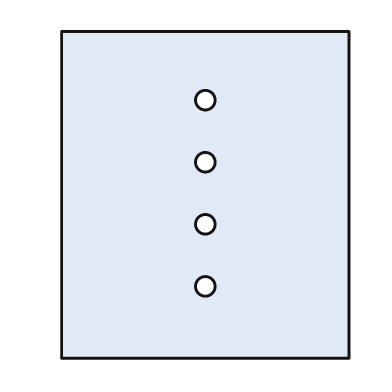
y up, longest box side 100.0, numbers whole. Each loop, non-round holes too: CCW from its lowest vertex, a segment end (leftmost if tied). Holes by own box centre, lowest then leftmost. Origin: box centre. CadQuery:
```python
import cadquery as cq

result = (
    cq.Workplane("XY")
    .moveTo(-44.0, -50.0)
    .lineTo(44.0, -50.0)
    .lineTo(44.0, 50.0)
    .lineTo(-44.0, 50.0)
    .close()
    .moveTo(0.0, -28.0)
    .circle(3.0)
    .moveTo(0.0, -9.0)
    .circle(3.0)
    .moveTo(0.0, 10.0)
    .circle(3.0)
    .moveTo(0.0, 29.0)
    .circle(3.0)
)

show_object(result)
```